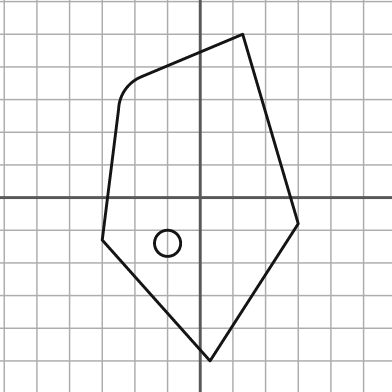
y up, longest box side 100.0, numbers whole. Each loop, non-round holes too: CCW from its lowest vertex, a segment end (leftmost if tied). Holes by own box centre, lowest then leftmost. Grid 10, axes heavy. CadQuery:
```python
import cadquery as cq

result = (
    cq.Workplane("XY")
    .moveTo(3.0, -50.0)
    .lineTo(30.0, -8.0)
    .lineTo(13.0, 50.0)
    .lineTo(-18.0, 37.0)
    .threePointArc((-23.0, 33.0), (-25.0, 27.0))
    .lineTo(-30.0, -13.0)
    .close()
    .moveTo(-10.0, -14.0)
    .circle(4.0)
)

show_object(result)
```